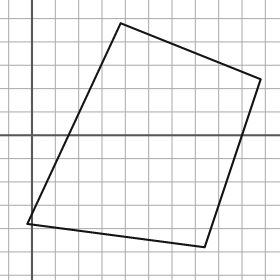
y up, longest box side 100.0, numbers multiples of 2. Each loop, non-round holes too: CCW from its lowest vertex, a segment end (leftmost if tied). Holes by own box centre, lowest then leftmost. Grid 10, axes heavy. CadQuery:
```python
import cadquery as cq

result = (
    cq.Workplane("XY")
    .moveTo(74.0, -48.0)
    .lineTo(98.0, 24.0)
    .lineTo(38.0, 48.0)
    .lineTo(-2.0, -38.0)
    .close()
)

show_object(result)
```